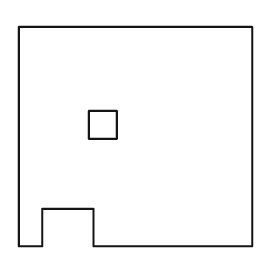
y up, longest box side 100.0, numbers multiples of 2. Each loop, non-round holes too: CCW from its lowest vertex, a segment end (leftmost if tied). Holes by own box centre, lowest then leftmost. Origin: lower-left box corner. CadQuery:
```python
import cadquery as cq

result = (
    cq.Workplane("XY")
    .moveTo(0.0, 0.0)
    .lineTo(10.0, 0.0)
    .lineTo(10.0, 16.0)
    .lineTo(32.0, 16.0)
    .lineTo(32.0, 0.0)
    .lineTo(100.0, 0.0)
    .lineTo(100.0, 94.0)
    .lineTo(0.0, 94.0)
    .close()
    .moveTo(30.0, 46.0)
    .lineTo(42.0, 46.0)
    .lineTo(42.0, 58.0)
    .lineTo(30.0, 58.0)
    .close()
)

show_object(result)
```